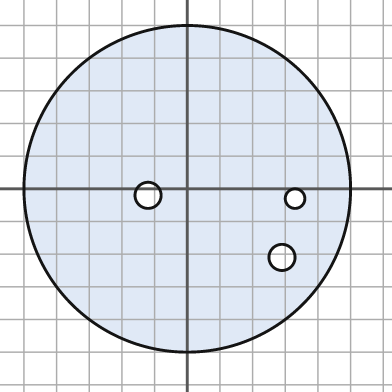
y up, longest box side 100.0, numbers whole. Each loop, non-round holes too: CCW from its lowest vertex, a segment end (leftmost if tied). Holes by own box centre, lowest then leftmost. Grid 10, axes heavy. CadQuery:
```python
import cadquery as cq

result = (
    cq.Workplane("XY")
    .moveTo(0.0, 0.0)
    .circle(50.0)
    .moveTo(29.0, -21.0)
    .circle(4.0)
    .moveTo(33.0, -3.0)
    .circle(3.0)
    .moveTo(-12.0, -2.0)
    .circle(4.0)
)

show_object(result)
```